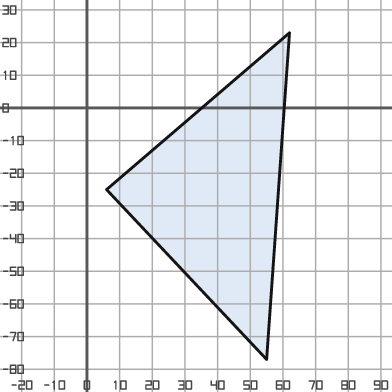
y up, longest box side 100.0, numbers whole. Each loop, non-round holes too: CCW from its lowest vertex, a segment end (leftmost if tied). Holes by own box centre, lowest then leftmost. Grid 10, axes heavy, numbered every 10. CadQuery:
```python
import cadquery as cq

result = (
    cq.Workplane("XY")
    .moveTo(55.0, -77.0)
    .lineTo(62.0, 23.0)
    .lineTo(6.0, -25.0)
    .close()
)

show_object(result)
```